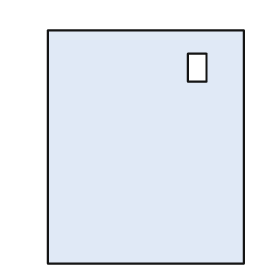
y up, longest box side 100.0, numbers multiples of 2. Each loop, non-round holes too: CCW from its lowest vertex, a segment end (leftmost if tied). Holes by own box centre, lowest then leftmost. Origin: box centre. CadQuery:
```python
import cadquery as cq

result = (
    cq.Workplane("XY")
    .moveTo(-42.0, -50.0)
    .lineTo(42.0, -50.0)
    .lineTo(42.0, 50.0)
    .lineTo(-42.0, 50.0)
    .close()
    .moveTo(18.0, 28.0)
    .lineTo(26.0, 28.0)
    .lineTo(26.0, 40.0)
    .lineTo(18.0, 40.0)
    .close()
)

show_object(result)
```